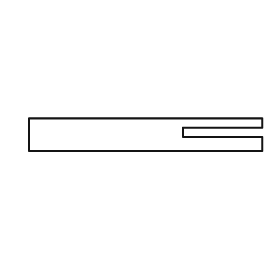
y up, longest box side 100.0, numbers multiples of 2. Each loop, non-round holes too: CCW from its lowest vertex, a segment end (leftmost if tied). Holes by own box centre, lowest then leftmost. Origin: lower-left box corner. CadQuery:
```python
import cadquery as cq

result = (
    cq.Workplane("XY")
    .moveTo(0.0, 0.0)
    .lineTo(100.0, 0.0)
    .lineTo(100.0, 6.0)
    .lineTo(66.0, 6.0)
    .lineTo(66.0, 10.0)
    .lineTo(100.0, 10.0)
    .lineTo(100.0, 14.0)
    .lineTo(0.0, 14.0)
    .close()
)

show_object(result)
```